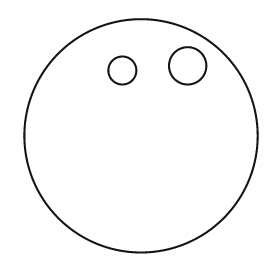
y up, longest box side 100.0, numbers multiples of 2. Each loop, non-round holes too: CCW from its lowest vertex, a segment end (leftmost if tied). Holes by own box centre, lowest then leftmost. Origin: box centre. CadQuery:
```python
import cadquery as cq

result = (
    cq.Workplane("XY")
    .moveTo(0.0, 0.0)
    .circle(50.0)
    .moveTo(-8.0, 28.0)
    .circle(6.0)
    .moveTo(20.0, 30.0)
    .circle(8.0)
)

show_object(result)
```